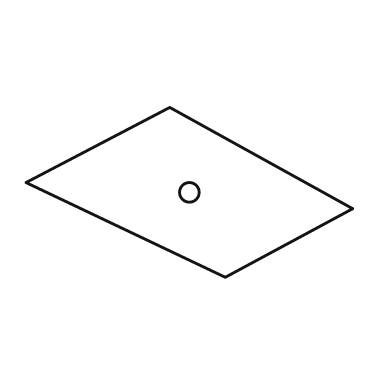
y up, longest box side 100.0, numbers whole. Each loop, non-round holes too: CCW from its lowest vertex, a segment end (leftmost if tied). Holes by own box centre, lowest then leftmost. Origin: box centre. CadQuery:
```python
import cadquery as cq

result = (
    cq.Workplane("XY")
    .moveTo(11.0, -26.0)
    .lineTo(50.0, -5.0)
    .lineTo(-6.0, 26.0)
    .lineTo(-50.0, 3.0)
    .close()
    .moveTo(0.0, 0.0)
    .circle(3.0)
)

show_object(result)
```